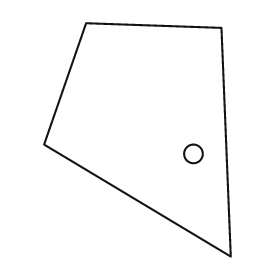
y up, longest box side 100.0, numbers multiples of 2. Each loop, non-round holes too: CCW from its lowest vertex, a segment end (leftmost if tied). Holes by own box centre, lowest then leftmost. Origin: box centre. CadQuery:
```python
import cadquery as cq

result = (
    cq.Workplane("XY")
    .moveTo(40.0, -50.0)
    .lineTo(36.0, 48.0)
    .lineTo(-22.0, 50.0)
    .lineTo(-40.0, -2.0)
    .close()
    .moveTo(24.0, -6.0)
    .circle(4.0)
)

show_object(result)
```